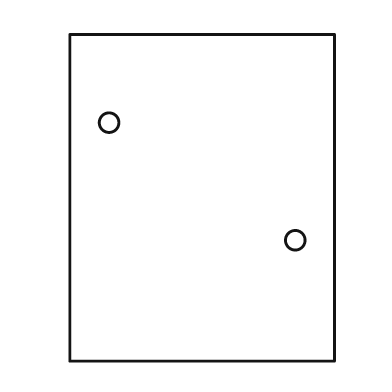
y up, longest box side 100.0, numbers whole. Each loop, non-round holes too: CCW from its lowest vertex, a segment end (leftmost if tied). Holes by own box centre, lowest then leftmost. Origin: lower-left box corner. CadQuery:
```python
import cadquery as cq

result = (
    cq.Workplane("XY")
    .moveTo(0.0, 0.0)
    .lineTo(81.0, 0.0)
    .lineTo(81.0, 100.0)
    .lineTo(0.0, 100.0)
    .close()
    .moveTo(69.0, 37.0)
    .circle(3.0)
    .moveTo(12.0, 73.0)
    .circle(3.0)
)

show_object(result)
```